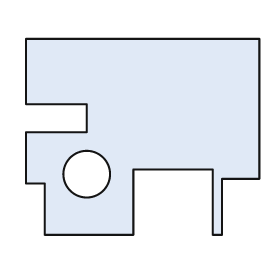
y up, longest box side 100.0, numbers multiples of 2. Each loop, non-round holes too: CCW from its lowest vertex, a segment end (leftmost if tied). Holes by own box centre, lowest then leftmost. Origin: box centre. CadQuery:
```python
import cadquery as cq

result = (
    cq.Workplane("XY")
    .moveTo(-42.0, -42.0)
    .lineTo(-4.0, -42.0)
    .lineTo(-4.0, -14.0)
    .lineTo(30.0, -14.0)
    .lineTo(30.0, -42.0)
    .lineTo(34.0, -42.0)
    .lineTo(34.0, -18.0)
    .lineTo(50.0, -18.0)
    .lineTo(50.0, 42.0)
    .lineTo(-50.0, 42.0)
    .lineTo(-50.0, 14.0)
    .lineTo(-24.0, 14.0)
    .lineTo(-24.0, 2.0)
    .lineTo(-50.0, 2.0)
    .lineTo(-50.0, -20.0)
    .lineTo(-42.0, -20.0)
    .close()
    .moveTo(-24.0, -16.0)
    .circle(10.0)
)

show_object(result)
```